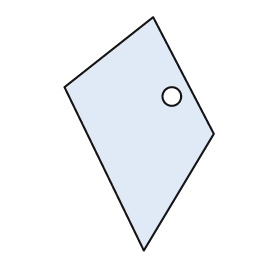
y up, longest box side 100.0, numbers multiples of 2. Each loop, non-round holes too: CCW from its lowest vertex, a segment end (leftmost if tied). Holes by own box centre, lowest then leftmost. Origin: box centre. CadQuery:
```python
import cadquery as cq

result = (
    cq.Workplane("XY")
    .moveTo(2.0, -50.0)
    .lineTo(32.0, 0.0)
    .lineTo(6.0, 50.0)
    .lineTo(-32.0, 20.0)
    .close()
    .moveTo(14.0, 16.0)
    .circle(4.0)
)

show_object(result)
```